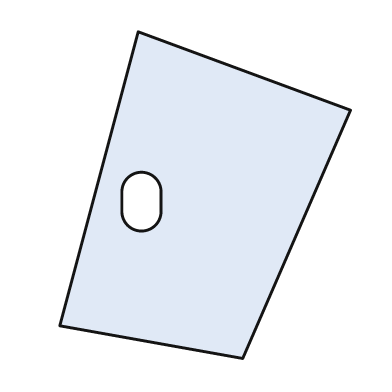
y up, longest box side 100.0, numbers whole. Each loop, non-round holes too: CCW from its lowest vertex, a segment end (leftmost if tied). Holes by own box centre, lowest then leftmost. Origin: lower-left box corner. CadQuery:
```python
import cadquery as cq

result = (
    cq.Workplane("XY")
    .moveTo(56.0, 0.0)
    .lineTo(89.0, 76.0)
    .lineTo(24.0, 100.0)
    .lineTo(0.0, 10.0)
    .close()
    .moveTo(19.0, 45.0)
    .threePointArc((25.0, 39.0), (31.0, 45.0))
    .lineTo(31.0, 51.0)
    .threePointArc((25.0, 57.0), (19.0, 51.0))
    .close()
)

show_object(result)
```